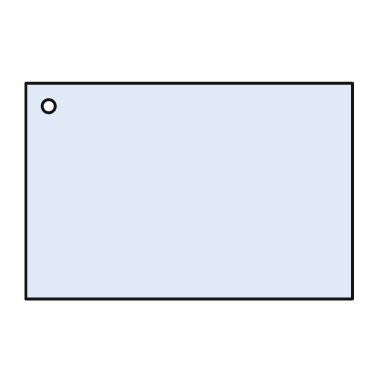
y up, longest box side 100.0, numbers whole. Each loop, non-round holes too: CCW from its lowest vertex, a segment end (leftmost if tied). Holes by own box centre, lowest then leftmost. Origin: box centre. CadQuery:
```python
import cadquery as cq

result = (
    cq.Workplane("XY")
    .moveTo(-50.0, -33.0)
    .lineTo(50.0, -33.0)
    .lineTo(50.0, 33.0)
    .lineTo(-50.0, 33.0)
    .close()
    .moveTo(-43.0, 26.0)
    .circle(2.0)
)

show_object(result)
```